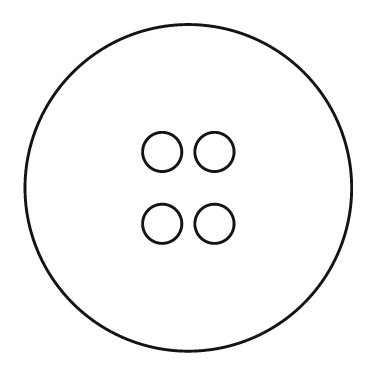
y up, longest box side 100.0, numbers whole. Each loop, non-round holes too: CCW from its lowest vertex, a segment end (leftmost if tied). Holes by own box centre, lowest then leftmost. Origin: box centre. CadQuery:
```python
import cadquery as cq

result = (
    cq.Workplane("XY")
    .moveTo(0.0, 0.0)
    .circle(50.0)
    .moveTo(-8.0, -11.0)
    .circle(6.0)
    .moveTo(8.0, -11.0)
    .circle(6.0)
    .moveTo(-8.0, 11.0)
    .circle(6.0)
    .moveTo(8.0, 11.0)
    .circle(6.0)
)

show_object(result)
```